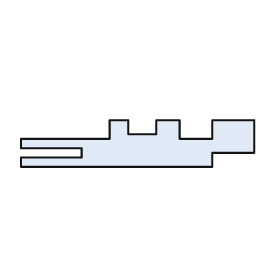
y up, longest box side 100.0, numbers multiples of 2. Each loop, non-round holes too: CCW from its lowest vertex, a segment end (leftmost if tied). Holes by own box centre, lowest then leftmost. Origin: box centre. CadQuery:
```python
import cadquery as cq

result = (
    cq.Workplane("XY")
    .moveTo(-50.0, -10.0)
    .lineTo(32.0, -10.0)
    .lineTo(32.0, -4.0)
    .lineTo(50.0, -4.0)
    .lineTo(50.0, 10.0)
    .lineTo(32.0, 10.0)
    .lineTo(32.0, 2.0)
    .lineTo(18.0, 2.0)
    .lineTo(18.0, 10.0)
    .lineTo(8.0, 10.0)
    .lineTo(8.0, 4.0)
    .lineTo(-4.0, 4.0)
    .lineTo(-4.0, 10.0)
    .lineTo(-12.0, 10.0)
    .lineTo(-12.0, 2.0)
    .lineTo(-50.0, 2.0)
    .lineTo(-50.0, -2.0)
    .lineTo(-24.0, -2.0)
    .lineTo(-24.0, -6.0)
    .lineTo(-50.0, -6.0)
    .close()
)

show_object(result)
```